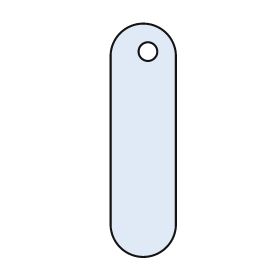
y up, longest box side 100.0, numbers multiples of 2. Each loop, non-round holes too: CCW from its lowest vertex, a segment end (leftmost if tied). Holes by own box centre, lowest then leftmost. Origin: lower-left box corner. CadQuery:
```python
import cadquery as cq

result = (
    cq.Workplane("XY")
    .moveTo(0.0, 14.0)
    .threePointArc((14.0, 0.0), (28.0, 14.0))
    .lineTo(28.0, 86.0)
    .threePointArc((14.0, 100.0), (0.0, 86.0))
    .close()
    .moveTo(16.0, 88.0)
    .circle(4.0)
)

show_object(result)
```